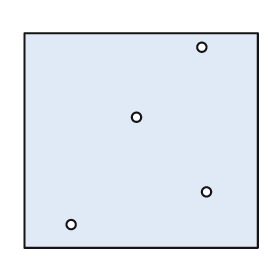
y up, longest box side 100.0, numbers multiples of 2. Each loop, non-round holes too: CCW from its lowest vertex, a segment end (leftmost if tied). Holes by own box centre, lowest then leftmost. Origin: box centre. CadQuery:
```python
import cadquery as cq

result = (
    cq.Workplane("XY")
    .moveTo(-50.0, -46.0)
    .lineTo(50.0, -46.0)
    .lineTo(50.0, 46.0)
    .lineTo(-50.0, 46.0)
    .close()
    .moveTo(-30.0, -36.0)
    .circle(2.0)
    .moveTo(28.0, -22.0)
    .circle(2.0)
    .moveTo(-2.0, 10.0)
    .circle(2.0)
    .moveTo(26.0, 40.0)
    .circle(2.0)
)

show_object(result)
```